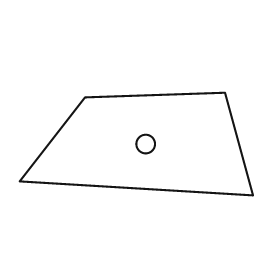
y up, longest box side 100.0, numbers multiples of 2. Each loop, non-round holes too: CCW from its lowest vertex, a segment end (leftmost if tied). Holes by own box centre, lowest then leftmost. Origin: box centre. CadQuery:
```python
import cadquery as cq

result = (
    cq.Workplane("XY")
    .moveTo(50.0, -22.0)
    .lineTo(38.0, 22.0)
    .lineTo(-22.0, 20.0)
    .lineTo(-50.0, -16.0)
    .close()
    .moveTo(4.0, 0.0)
    .circle(4.0)
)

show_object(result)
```